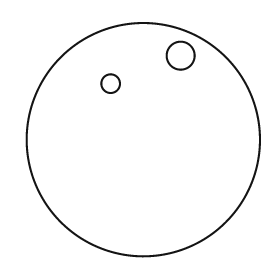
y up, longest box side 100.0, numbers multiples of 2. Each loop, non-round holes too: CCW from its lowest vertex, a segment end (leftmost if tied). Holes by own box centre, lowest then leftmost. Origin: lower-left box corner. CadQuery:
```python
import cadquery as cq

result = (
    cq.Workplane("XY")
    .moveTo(50.0, 50.0)
    .circle(50.0)
    .moveTo(36.0, 74.0)
    .circle(4.0)
    .moveTo(66.0, 86.0)
    .circle(6.0)
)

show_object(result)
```